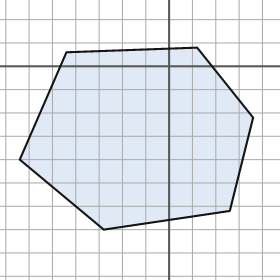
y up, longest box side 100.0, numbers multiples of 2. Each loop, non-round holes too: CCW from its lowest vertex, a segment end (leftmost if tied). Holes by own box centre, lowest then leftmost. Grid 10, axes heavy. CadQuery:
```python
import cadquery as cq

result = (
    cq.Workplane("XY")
    .moveTo(-28.0, -70.0)
    .lineTo(26.0, -62.0)
    .lineTo(36.0, -22.0)
    .lineTo(12.0, 8.0)
    .lineTo(-44.0, 6.0)
    .lineTo(-64.0, -40.0)
    .close()
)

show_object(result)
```